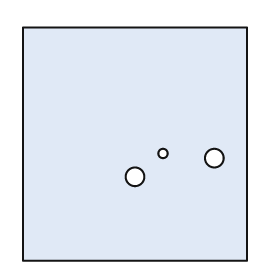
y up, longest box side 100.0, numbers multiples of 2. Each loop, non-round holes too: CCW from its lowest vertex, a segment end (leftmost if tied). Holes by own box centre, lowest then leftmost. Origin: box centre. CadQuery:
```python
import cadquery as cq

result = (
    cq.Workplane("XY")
    .moveTo(-48.0, -50.0)
    .lineTo(48.0, -50.0)
    .lineTo(48.0, 50.0)
    .lineTo(-48.0, 50.0)
    .close()
    .moveTo(0.0, -14.0)
    .circle(4.0)
    .moveTo(34.0, -6.0)
    .circle(4.0)
    .moveTo(12.0, -4.0)
    .circle(2.0)
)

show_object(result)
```